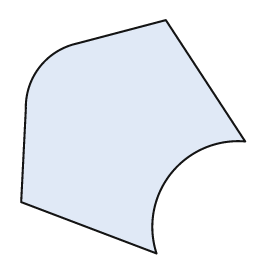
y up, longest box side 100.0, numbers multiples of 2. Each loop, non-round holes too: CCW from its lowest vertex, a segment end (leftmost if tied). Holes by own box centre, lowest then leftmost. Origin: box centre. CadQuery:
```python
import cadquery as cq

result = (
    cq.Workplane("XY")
    .moveTo(10.0, -50.0)
    .threePointArc((16.0, -16.0), (48.0, -2.0))
    .lineTo(14.0, 50.0)
    .lineTo(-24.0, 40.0)
    .threePointArc((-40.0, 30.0), (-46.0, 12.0))
    .lineTo(-48.0, -28.0)
    .close()
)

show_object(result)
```